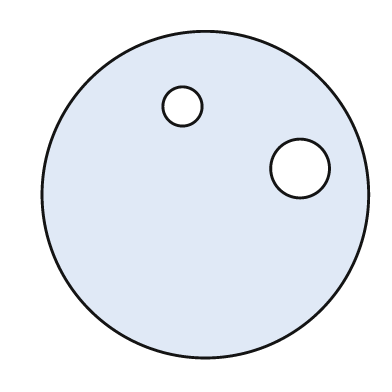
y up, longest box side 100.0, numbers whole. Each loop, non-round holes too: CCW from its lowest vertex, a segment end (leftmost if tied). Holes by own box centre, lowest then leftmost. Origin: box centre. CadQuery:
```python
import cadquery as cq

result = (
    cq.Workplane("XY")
    .moveTo(0.0, 0.0)
    .circle(50.0)
    .moveTo(29.0, 8.0)
    .circle(9.0)
    .moveTo(-7.0, 27.0)
    .circle(6.0)
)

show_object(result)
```